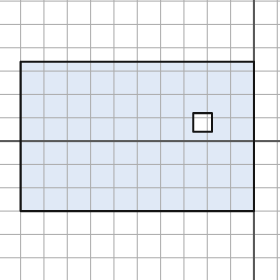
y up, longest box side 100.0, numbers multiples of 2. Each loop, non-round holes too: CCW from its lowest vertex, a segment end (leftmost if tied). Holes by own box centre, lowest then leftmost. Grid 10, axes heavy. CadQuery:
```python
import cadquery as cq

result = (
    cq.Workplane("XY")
    .moveTo(-100.0, -30.0)
    .lineTo(0.0, -30.0)
    .lineTo(0.0, 34.0)
    .lineTo(-100.0, 34.0)
    .close()
    .moveTo(-26.0, 4.0)
    .lineTo(-18.0, 4.0)
    .lineTo(-18.0, 12.0)
    .lineTo(-26.0, 12.0)
    .close()
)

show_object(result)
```